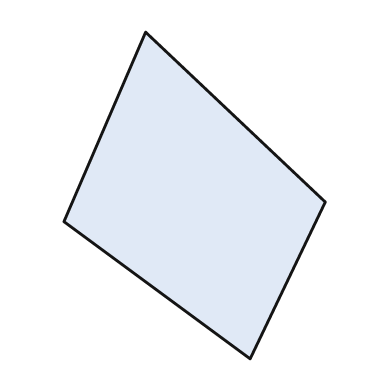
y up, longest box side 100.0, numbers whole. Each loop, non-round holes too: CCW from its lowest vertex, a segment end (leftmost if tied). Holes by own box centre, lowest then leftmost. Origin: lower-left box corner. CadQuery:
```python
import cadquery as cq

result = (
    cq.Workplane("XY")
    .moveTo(57.0, 0.0)
    .lineTo(80.0, 48.0)
    .lineTo(25.0, 100.0)
    .lineTo(0.0, 42.0)
    .close()
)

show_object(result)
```